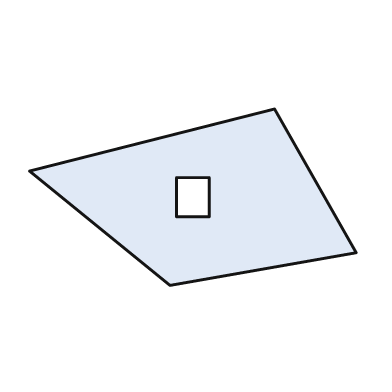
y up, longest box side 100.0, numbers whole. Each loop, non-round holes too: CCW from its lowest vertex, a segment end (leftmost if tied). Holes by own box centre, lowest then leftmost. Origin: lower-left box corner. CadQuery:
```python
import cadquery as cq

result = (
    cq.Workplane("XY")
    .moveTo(43.0, 0.0)
    .lineTo(100.0, 10.0)
    .lineTo(75.0, 54.0)
    .lineTo(0.0, 35.0)
    .close()
    .moveTo(45.0, 21.0)
    .lineTo(55.0, 21.0)
    .lineTo(55.0, 33.0)
    .lineTo(45.0, 33.0)
    .close()
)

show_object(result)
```